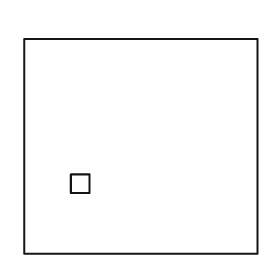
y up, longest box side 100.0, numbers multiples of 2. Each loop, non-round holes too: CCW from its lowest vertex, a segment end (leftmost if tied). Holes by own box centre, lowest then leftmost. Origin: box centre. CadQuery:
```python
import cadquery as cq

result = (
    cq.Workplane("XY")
    .moveTo(-50.0, -46.0)
    .lineTo(50.0, -46.0)
    .lineTo(50.0, 46.0)
    .lineTo(-50.0, 46.0)
    .close()
    .moveTo(-30.0, -20.0)
    .lineTo(-22.0, -20.0)
    .lineTo(-22.0, -12.0)
    .lineTo(-30.0, -12.0)
    .close()
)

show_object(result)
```